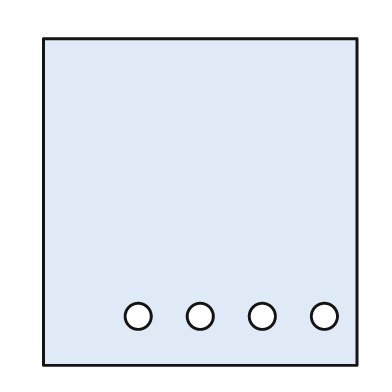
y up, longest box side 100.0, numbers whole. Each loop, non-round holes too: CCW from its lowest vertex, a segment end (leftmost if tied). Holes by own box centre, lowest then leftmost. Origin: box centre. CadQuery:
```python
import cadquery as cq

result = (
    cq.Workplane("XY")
    .moveTo(-48.0, -50.0)
    .lineTo(48.0, -50.0)
    .lineTo(48.0, 50.0)
    .lineTo(-48.0, 50.0)
    .close()
    .moveTo(-19.0, -35.0)
    .circle(4.0)
    .moveTo(0.0, -35.0)
    .circle(4.0)
    .moveTo(19.0, -35.0)
    .circle(4.0)
    .moveTo(38.0, -35.0)
    .circle(4.0)
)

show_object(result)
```